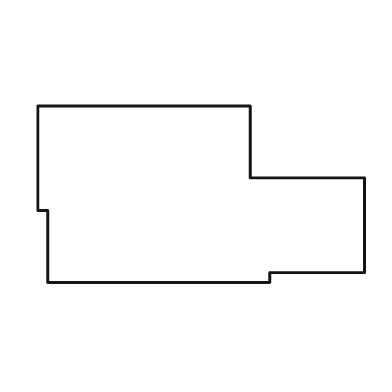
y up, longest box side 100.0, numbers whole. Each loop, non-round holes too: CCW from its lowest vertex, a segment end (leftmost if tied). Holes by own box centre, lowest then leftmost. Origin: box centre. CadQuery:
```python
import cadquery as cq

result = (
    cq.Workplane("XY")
    .moveTo(-47.0, -27.0)
    .lineTo(21.0, -27.0)
    .lineTo(21.0, -24.0)
    .lineTo(50.0, -24.0)
    .lineTo(50.0, 5.0)
    .lineTo(15.0, 5.0)
    .lineTo(15.0, 27.0)
    .lineTo(-50.0, 27.0)
    .lineTo(-50.0, -5.0)
    .lineTo(-47.0, -5.0)
    .close()
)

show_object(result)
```